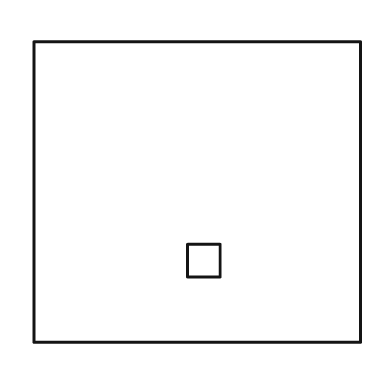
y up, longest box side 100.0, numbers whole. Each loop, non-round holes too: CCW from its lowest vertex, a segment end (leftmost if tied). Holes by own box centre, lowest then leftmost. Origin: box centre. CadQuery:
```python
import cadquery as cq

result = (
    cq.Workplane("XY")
    .moveTo(-50.0, -46.0)
    .lineTo(50.0, -46.0)
    .lineTo(50.0, 46.0)
    .lineTo(-50.0, 46.0)
    .close()
    .moveTo(-3.0, -26.0)
    .lineTo(7.0, -26.0)
    .lineTo(7.0, -16.0)
    .lineTo(-3.0, -16.0)
    .close()
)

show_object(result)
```